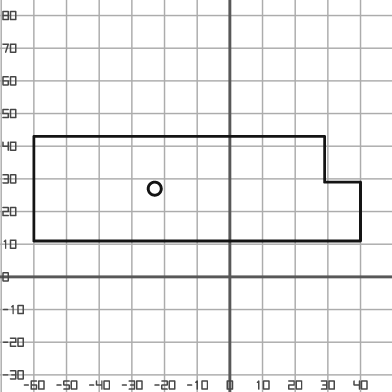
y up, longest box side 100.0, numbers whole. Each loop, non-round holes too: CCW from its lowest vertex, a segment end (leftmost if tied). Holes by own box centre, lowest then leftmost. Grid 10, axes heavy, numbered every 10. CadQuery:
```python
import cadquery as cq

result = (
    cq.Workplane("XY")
    .moveTo(-60.0, 11.0)
    .lineTo(40.0, 11.0)
    .lineTo(40.0, 29.0)
    .lineTo(29.0, 29.0)
    .lineTo(29.0, 43.0)
    .lineTo(-60.0, 43.0)
    .close()
    .moveTo(-23.0, 27.0)
    .circle(2.0)
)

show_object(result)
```